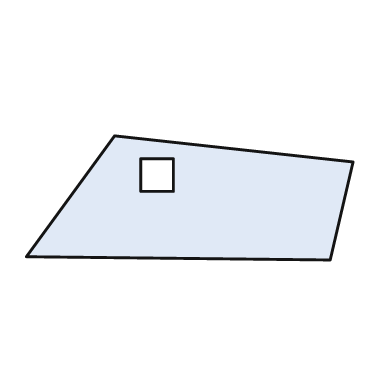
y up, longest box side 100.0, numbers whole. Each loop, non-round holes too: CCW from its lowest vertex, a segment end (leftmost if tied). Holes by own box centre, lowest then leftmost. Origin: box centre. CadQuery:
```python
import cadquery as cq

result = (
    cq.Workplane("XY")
    .moveTo(43.0, -19.0)
    .lineTo(50.0, 11.0)
    .lineTo(-23.0, 19.0)
    .lineTo(-50.0, -18.0)
    .close()
    .moveTo(-15.0, 2.0)
    .lineTo(-5.0, 2.0)
    .lineTo(-5.0, 12.0)
    .lineTo(-15.0, 12.0)
    .close()
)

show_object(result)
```